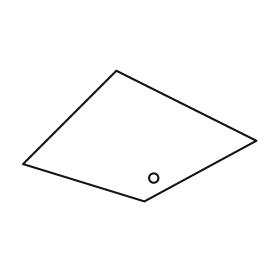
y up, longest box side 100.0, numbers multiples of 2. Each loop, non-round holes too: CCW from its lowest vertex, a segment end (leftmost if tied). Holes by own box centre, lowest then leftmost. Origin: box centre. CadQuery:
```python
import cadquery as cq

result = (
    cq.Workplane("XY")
    .moveTo(2.0, -28.0)
    .lineTo(50.0, -2.0)
    .lineTo(-10.0, 28.0)
    .lineTo(-50.0, -12.0)
    .close()
    .moveTo(6.0, -18.0)
    .circle(2.0)
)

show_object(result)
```